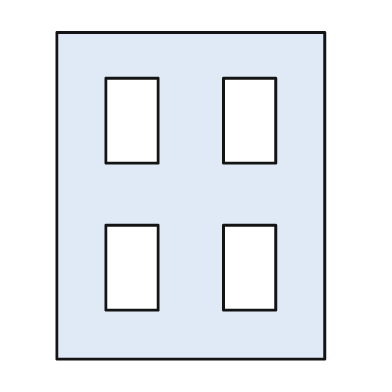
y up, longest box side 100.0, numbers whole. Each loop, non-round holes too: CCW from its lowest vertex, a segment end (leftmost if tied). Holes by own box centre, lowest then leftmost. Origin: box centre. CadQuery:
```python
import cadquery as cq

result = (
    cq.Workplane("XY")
    .moveTo(-41.0, -50.0)
    .lineTo(41.0, -50.0)
    .lineTo(41.0, 50.0)
    .lineTo(-41.0, 50.0)
    .close()
    .moveTo(-26.0, -35.0)
    .lineTo(-10.0, -35.0)
    .lineTo(-10.0, -9.0)
    .lineTo(-26.0, -9.0)
    .close()
    .moveTo(10.0, -35.0)
    .lineTo(26.0, -35.0)
    .lineTo(26.0, -9.0)
    .lineTo(10.0, -9.0)
    .close()
    .moveTo(-26.0, 10.0)
    .lineTo(-10.0, 10.0)
    .lineTo(-10.0, 36.0)
    .lineTo(-26.0, 36.0)
    .close()
    .moveTo(10.0, 10.0)
    .lineTo(26.0, 10.0)
    .lineTo(26.0, 36.0)
    .lineTo(10.0, 36.0)
    .close()
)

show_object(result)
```